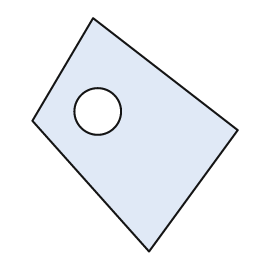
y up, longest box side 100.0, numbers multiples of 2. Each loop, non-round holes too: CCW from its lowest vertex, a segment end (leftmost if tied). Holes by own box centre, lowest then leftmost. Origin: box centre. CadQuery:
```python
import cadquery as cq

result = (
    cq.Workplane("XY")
    .moveTo(6.0, -50.0)
    .lineTo(44.0, 2.0)
    .lineTo(-18.0, 50.0)
    .lineTo(-44.0, 6.0)
    .close()
    .moveTo(-16.0, 10.0)
    .circle(10.0)
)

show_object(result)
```